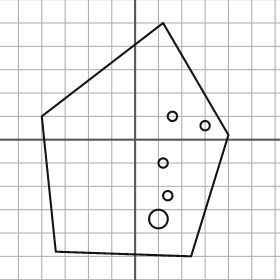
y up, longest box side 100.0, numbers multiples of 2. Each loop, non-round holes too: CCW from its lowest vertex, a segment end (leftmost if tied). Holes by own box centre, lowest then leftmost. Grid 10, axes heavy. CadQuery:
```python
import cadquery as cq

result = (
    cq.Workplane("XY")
    .moveTo(24.0, -50.0)
    .lineTo(40.0, 2.0)
    .lineTo(12.0, 50.0)
    .lineTo(-40.0, 10.0)
    .lineTo(-34.0, -48.0)
    .close()
    .moveTo(10.0, -34.0)
    .circle(4.0)
    .moveTo(14.0, -24.0)
    .circle(2.0)
    .moveTo(12.0, -10.0)
    .circle(2.0)
    .moveTo(30.0, 6.0)
    .circle(2.0)
    .moveTo(16.0, 10.0)
    .circle(2.0)
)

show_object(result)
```